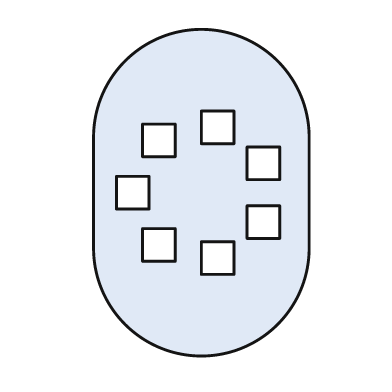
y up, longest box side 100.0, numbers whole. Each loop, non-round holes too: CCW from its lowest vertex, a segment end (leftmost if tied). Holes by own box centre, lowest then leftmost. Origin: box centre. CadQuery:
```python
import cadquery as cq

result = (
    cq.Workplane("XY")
    .moveTo(-33.0, -17.0)
    .threePointArc((0.0, -50.0), (33.0, -17.0))
    .lineTo(33.0, 17.0)
    .threePointArc((0.0, 50.0), (-33.0, 17.0))
    .close()
    .moveTo(0.0, -25.0)
    .lineTo(10.0, -25.0)
    .lineTo(10.0, -15.0)
    .lineTo(0.0, -15.0)
    .close()
    .moveTo(-18.0, -21.0)
    .lineTo(-8.0, -21.0)
    .lineTo(-8.0, -11.0)
    .lineTo(-18.0, -11.0)
    .close()
    .moveTo(14.0, -14.0)
    .lineTo(24.0, -14.0)
    .lineTo(24.0, -4.0)
    .lineTo(14.0, -4.0)
    .close()
    .moveTo(-26.0, -5.0)
    .lineTo(-16.0, -5.0)
    .lineTo(-16.0, 5.0)
    .lineTo(-26.0, 5.0)
    .close()
    .moveTo(14.0, 4.0)
    .lineTo(24.0, 4.0)
    .lineTo(24.0, 14.0)
    .lineTo(14.0, 14.0)
    .close()
    .moveTo(-18.0, 11.0)
    .lineTo(-8.0, 11.0)
    .lineTo(-8.0, 21.0)
    .lineTo(-18.0, 21.0)
    .close()
    .moveTo(0.0, 15.0)
    .lineTo(10.0, 15.0)
    .lineTo(10.0, 25.0)
    .lineTo(0.0, 25.0)
    .close()
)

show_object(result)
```